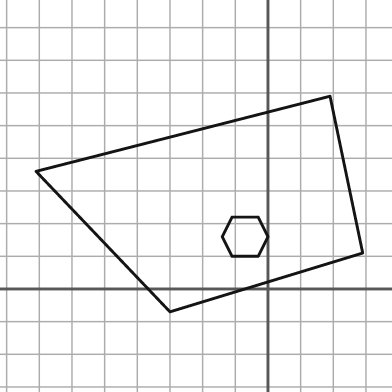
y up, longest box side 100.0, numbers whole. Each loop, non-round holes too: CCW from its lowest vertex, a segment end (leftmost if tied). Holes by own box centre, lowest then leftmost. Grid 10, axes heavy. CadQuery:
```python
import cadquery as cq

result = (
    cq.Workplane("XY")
    .moveTo(-30.0, -7.0)
    .lineTo(29.0, 11.0)
    .lineTo(19.0, 59.0)
    .lineTo(-71.0, 36.0)
    .close()
    .moveTo(-11.0, 10.0)
    .lineTo(-3.0, 10.0)
    .lineTo(0.0, 16.0)
    .lineTo(-3.0, 22.0)
    .lineTo(-11.0, 22.0)
    .lineTo(-14.0, 16.0)
    .close()
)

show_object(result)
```